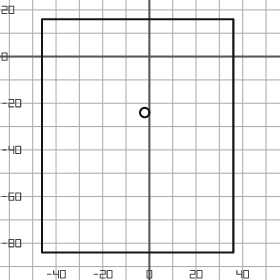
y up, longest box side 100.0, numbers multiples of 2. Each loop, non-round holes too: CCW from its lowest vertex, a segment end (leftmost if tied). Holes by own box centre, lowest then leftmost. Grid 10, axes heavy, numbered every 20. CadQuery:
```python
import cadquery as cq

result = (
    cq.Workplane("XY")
    .moveTo(-46.0, -84.0)
    .lineTo(36.0, -84.0)
    .lineTo(36.0, 16.0)
    .lineTo(-46.0, 16.0)
    .close()
    .moveTo(-2.0, -24.0)
    .circle(2.0)
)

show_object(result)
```